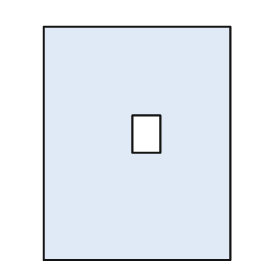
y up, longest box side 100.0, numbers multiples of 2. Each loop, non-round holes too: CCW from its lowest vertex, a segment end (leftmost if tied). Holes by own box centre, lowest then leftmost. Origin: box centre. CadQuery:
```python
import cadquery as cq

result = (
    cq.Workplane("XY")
    .moveTo(-40.0, -50.0)
    .lineTo(40.0, -50.0)
    .lineTo(40.0, 50.0)
    .lineTo(-40.0, 50.0)
    .close()
    .moveTo(-2.0, -4.0)
    .lineTo(10.0, -4.0)
    .lineTo(10.0, 12.0)
    .lineTo(-2.0, 12.0)
    .close()
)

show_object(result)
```